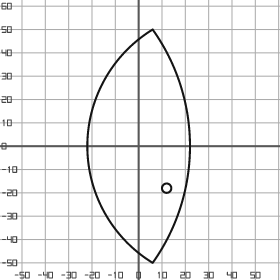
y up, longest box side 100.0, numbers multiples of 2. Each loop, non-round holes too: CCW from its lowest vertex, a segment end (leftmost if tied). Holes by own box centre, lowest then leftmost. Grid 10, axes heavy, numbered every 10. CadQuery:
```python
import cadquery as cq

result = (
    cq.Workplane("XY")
    .moveTo(6.0, -50.0)
    .threePointArc((22.0, 0.0), (6.0, 50.0))
    .threePointArc((-22.0, 0.0), (6.0, -50.0))
    .close()
    .moveTo(12.0, -18.0)
    .circle(2.0)
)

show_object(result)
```